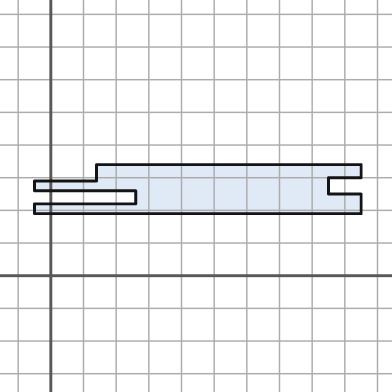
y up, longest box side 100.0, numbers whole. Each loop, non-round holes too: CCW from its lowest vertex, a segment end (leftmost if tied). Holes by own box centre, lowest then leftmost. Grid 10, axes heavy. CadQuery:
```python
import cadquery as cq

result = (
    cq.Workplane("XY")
    .moveTo(-5.0, 19.0)
    .lineTo(95.0, 19.0)
    .lineTo(95.0, 25.0)
    .lineTo(85.0, 25.0)
    .lineTo(85.0, 30.0)
    .lineTo(95.0, 30.0)
    .lineTo(95.0, 34.0)
    .lineTo(14.0, 34.0)
    .lineTo(14.0, 29.0)
    .lineTo(-5.0, 29.0)
    .lineTo(-5.0, 26.0)
    .lineTo(26.0, 26.0)
    .lineTo(26.0, 22.0)
    .lineTo(-5.0, 22.0)
    .close()
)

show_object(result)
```